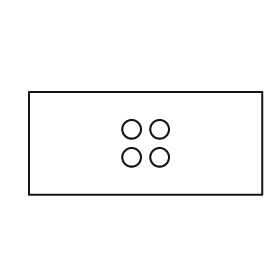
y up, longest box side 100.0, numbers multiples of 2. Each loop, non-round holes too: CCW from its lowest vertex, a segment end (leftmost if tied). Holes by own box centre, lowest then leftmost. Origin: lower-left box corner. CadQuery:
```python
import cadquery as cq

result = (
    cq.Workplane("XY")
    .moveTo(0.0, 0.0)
    .lineTo(100.0, 0.0)
    .lineTo(100.0, 44.0)
    .lineTo(0.0, 44.0)
    .close()
    .moveTo(44.0, 16.0)
    .circle(4.0)
    .moveTo(56.0, 16.0)
    .circle(4.0)
    .moveTo(44.0, 28.0)
    .circle(4.0)
    .moveTo(56.0, 28.0)
    .circle(4.0)
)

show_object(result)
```